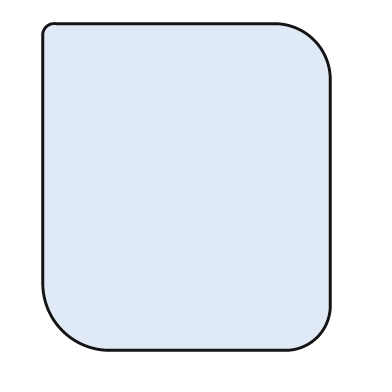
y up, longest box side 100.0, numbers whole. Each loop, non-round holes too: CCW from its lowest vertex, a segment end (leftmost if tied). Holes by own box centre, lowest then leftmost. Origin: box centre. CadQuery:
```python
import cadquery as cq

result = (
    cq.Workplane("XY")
    .moveTo(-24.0, -50.0)
    .lineTo(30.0, -50.0)
    .threePointArc((40.0, -46.0), (44.0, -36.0))
    .lineTo(44.0, 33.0)
    .threePointArc((39.0, 45.0), (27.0, 50.0))
    .lineTo(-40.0, 50.0)
    .threePointArc((-43.0, 49.0), (-44.0, 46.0))
    .lineTo(-44.0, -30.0)
    .threePointArc((-38.0, -44.0), (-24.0, -50.0))
    .close()
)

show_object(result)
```